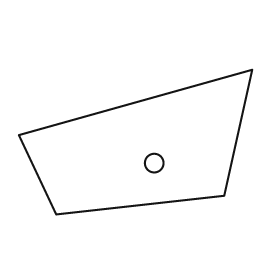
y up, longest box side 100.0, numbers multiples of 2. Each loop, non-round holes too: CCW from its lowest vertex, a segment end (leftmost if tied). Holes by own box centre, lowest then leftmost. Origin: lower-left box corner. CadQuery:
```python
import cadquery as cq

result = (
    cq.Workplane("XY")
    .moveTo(16.0, 0.0)
    .lineTo(88.0, 8.0)
    .lineTo(100.0, 62.0)
    .lineTo(0.0, 34.0)
    .close()
    .moveTo(58.0, 22.0)
    .circle(4.0)
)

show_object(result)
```